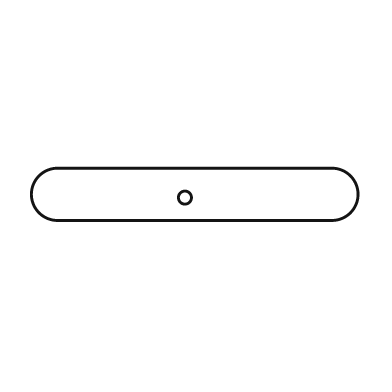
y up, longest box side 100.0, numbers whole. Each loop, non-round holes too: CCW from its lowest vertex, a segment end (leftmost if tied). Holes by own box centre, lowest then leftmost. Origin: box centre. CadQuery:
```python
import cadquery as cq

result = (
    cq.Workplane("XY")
    .moveTo(-42.0, -8.0)
    .lineTo(42.0, -8.0)
    .threePointArc((50.0, 0.0), (42.0, 8.0))
    .lineTo(-42.0, 8.0)
    .threePointArc((-50.0, 0.0), (-42.0, -8.0))
    .close()
    .moveTo(-3.0, -1.0)
    .circle(2.0)
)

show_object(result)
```